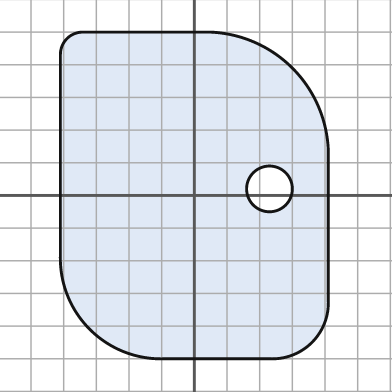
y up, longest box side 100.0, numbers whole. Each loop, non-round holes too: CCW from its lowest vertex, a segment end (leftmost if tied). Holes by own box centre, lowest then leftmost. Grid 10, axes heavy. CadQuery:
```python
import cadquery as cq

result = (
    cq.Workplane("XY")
    .moveTo(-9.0, -50.0)
    .lineTo(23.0, -50.0)
    .threePointArc((36.0, -45.0), (41.0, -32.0))
    .lineTo(41.0, 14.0)
    .threePointArc((30.0, 39.0), (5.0, 50.0))
    .lineTo(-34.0, 50.0)
    .threePointArc((-39.0, 48.0), (-41.0, 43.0))
    .lineTo(-41.0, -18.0)
    .threePointArc((-32.0, -41.0), (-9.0, -50.0))
    .close()
    .moveTo(23.0, 2.0)
    .circle(7.0)
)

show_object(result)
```